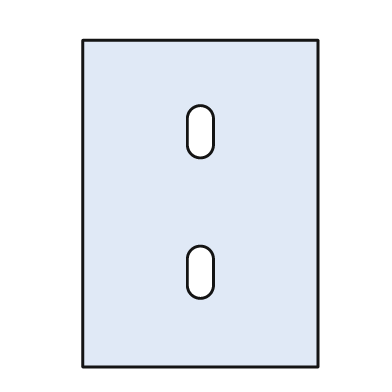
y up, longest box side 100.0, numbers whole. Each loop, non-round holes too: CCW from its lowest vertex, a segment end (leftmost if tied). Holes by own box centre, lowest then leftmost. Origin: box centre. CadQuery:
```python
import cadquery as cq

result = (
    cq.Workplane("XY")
    .moveTo(-36.0, -50.0)
    .lineTo(36.0, -50.0)
    .lineTo(36.0, 50.0)
    .lineTo(-36.0, 50.0)
    .close()
    .moveTo(-4.0, -25.0)
    .threePointArc((0.0, -29.0), (4.0, -25.0))
    .lineTo(4.0, -17.0)
    .threePointArc((0.0, -13.0), (-4.0, -17.0))
    .close()
    .moveTo(-4.0, 18.0)
    .threePointArc((0.0, 14.0), (4.0, 18.0))
    .lineTo(4.0, 26.0)
    .threePointArc((0.0, 30.0), (-4.0, 26.0))
    .close()
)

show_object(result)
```